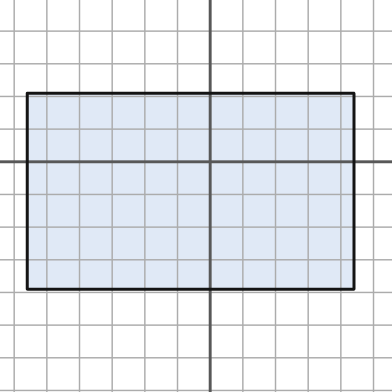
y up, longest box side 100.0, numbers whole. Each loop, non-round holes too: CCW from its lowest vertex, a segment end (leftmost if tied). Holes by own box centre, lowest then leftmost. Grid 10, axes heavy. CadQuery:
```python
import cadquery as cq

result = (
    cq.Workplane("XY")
    .moveTo(-56.0, -39.0)
    .lineTo(44.0, -39.0)
    .lineTo(44.0, 21.0)
    .lineTo(-56.0, 21.0)
    .close()
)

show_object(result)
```